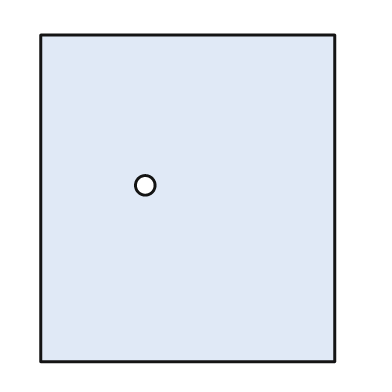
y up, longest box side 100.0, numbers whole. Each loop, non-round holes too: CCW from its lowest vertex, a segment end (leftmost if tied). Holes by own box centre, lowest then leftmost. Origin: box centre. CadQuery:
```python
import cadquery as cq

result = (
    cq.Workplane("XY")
    .moveTo(-45.0, -50.0)
    .lineTo(45.0, -50.0)
    .lineTo(45.0, 50.0)
    .lineTo(-45.0, 50.0)
    .close()
    .moveTo(-13.0, 4.0)
    .circle(3.0)
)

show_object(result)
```